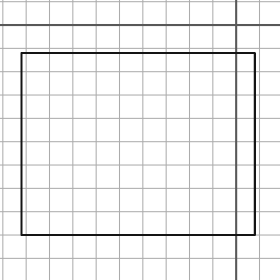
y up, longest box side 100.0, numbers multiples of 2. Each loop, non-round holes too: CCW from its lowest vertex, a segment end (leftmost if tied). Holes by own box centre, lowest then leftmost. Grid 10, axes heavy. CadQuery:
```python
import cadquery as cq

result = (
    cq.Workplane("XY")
    .moveTo(-92.0, -90.0)
    .lineTo(8.0, -90.0)
    .lineTo(8.0, -12.0)
    .lineTo(-92.0, -12.0)
    .close()
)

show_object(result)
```